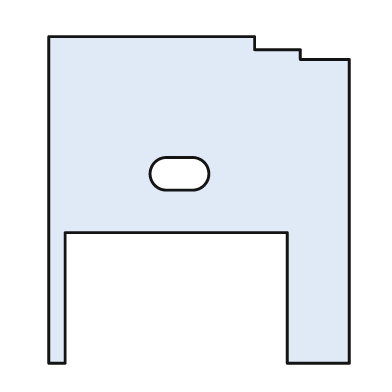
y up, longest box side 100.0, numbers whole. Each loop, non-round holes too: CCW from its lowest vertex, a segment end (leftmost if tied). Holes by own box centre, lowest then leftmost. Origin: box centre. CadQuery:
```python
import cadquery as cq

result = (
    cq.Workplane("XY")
    .moveTo(-46.0, -50.0)
    .lineTo(-41.0, -50.0)
    .lineTo(-41.0, -10.0)
    .lineTo(27.0, -10.0)
    .lineTo(27.0, -50.0)
    .lineTo(46.0, -50.0)
    .lineTo(46.0, 43.0)
    .lineTo(31.0, 43.0)
    .lineTo(31.0, 46.0)
    .lineTo(17.0, 46.0)
    .lineTo(17.0, 50.0)
    .lineTo(-46.0, 50.0)
    .close()
    .moveTo(-10.0, 3.0)
    .lineTo(-2.0, 3.0)
    .threePointArc((3.0, 8.0), (-2.0, 13.0))
    .lineTo(-10.0, 13.0)
    .threePointArc((-15.0, 8.0), (-10.0, 3.0))
    .close()
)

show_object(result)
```